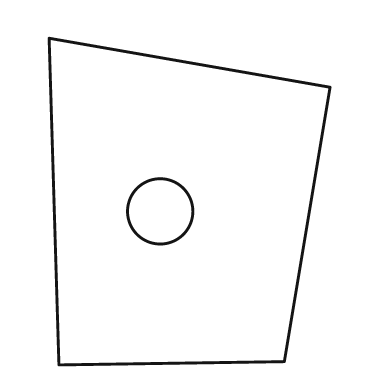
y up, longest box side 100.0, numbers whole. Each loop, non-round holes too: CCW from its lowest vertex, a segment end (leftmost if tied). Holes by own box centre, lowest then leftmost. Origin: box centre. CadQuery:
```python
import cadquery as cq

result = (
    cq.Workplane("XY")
    .moveTo(-40.0, -50.0)
    .lineTo(29.0, -49.0)
    .lineTo(43.0, 35.0)
    .lineTo(-43.0, 50.0)
    .close()
    .moveTo(-9.0, -3.0)
    .circle(10.0)
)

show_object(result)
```